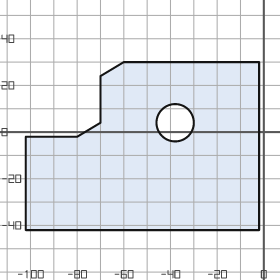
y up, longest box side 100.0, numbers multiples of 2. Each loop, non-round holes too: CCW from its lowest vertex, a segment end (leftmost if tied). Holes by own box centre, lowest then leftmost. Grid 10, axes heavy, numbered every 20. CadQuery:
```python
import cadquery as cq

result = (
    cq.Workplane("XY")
    .moveTo(-102.0, -42.0)
    .lineTo(-2.0, -42.0)
    .lineTo(-2.0, 30.0)
    .lineTo(-60.0, 30.0)
    .lineTo(-70.0, 24.0)
    .lineTo(-70.0, 4.0)
    .lineTo(-80.0, -2.0)
    .lineTo(-102.0, -2.0)
    .close()
    .moveTo(-38.0, 4.0)
    .circle(8.0)
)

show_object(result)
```